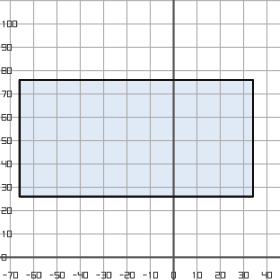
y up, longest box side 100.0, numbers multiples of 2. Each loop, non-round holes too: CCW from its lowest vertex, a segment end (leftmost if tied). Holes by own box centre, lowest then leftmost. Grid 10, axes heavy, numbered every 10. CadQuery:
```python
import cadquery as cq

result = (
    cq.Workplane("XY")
    .moveTo(-66.0, 26.0)
    .lineTo(34.0, 26.0)
    .lineTo(34.0, 76.0)
    .lineTo(-66.0, 76.0)
    .close()
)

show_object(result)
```